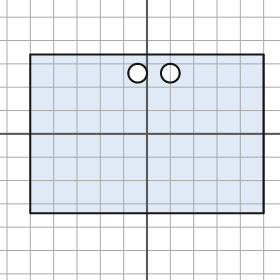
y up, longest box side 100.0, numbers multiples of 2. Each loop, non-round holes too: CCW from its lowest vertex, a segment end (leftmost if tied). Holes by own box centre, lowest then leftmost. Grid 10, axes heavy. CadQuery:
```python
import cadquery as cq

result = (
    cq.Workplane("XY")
    .moveTo(-50.0, -34.0)
    .lineTo(50.0, -34.0)
    .lineTo(50.0, 34.0)
    .lineTo(-50.0, 34.0)
    .close()
    .moveTo(-4.0, 26.0)
    .circle(4.0)
    .moveTo(10.0, 26.0)
    .circle(4.0)
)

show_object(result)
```